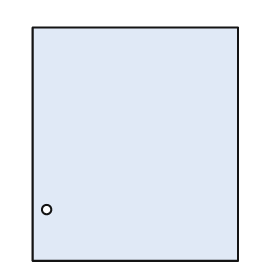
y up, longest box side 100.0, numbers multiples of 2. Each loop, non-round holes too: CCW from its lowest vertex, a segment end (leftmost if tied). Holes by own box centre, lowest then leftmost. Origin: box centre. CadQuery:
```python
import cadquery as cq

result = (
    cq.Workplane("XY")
    .moveTo(-44.0, -50.0)
    .lineTo(44.0, -50.0)
    .lineTo(44.0, 50.0)
    .lineTo(-44.0, 50.0)
    .close()
    .moveTo(-38.0, -28.0)
    .circle(2.0)
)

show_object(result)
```